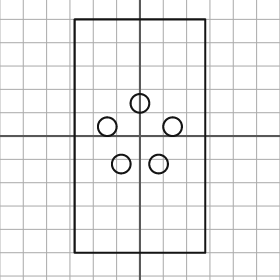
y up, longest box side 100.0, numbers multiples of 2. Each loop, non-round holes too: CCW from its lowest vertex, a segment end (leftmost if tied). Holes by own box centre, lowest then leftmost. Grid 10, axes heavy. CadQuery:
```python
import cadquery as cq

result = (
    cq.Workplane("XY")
    .moveTo(-28.0, -50.0)
    .lineTo(28.0, -50.0)
    .lineTo(28.0, 50.0)
    .lineTo(-28.0, 50.0)
    .close()
    .moveTo(-8.0, -12.0)
    .circle(4.0)
    .moveTo(8.0, -12.0)
    .circle(4.0)
    .moveTo(-14.0, 4.0)
    .circle(4.0)
    .moveTo(14.0, 4.0)
    .circle(4.0)
    .moveTo(0.0, 14.0)
    .circle(4.0)
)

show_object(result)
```